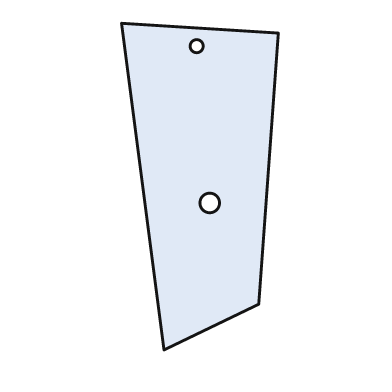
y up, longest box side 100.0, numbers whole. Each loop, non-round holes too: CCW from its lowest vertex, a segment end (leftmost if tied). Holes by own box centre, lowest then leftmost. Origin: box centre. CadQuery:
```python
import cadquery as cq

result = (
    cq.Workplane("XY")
    .moveTo(-11.0, -50.0)
    .lineTo(18.0, -36.0)
    .lineTo(24.0, 47.0)
    .lineTo(-24.0, 50.0)
    .close()
    .moveTo(3.0, -5.0)
    .circle(3.0)
    .moveTo(-1.0, 43.0)
    .circle(2.0)
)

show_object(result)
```